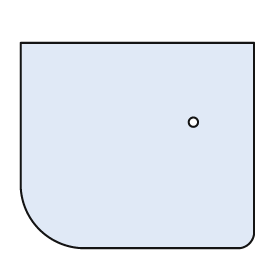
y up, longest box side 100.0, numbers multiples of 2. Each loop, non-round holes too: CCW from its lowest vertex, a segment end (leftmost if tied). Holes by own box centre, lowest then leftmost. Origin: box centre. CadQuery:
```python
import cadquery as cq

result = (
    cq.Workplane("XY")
    .moveTo(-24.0, -44.0)
    .lineTo(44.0, -44.0)
    .threePointArc((48.0, -42.0), (50.0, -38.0))
    .lineTo(50.0, 44.0)
    .lineTo(-50.0, 44.0)
    .lineTo(-50.0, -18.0)
    .threePointArc((-42.0, -36.0), (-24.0, -44.0))
    .close()
    .moveTo(24.0, 10.0)
    .circle(2.0)
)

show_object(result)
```